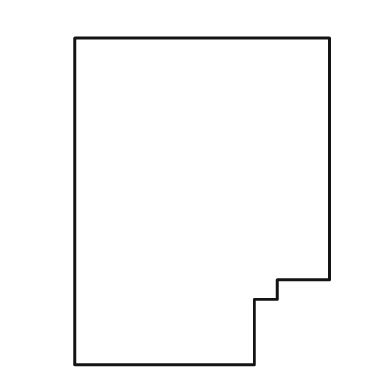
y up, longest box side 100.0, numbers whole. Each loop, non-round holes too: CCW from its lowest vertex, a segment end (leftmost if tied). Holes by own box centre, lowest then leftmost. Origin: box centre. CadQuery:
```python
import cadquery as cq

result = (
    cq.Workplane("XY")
    .moveTo(-39.0, -50.0)
    .lineTo(16.0, -50.0)
    .lineTo(16.0, -30.0)
    .lineTo(23.0, -30.0)
    .lineTo(23.0, -24.0)
    .lineTo(39.0, -24.0)
    .lineTo(39.0, 50.0)
    .lineTo(-39.0, 50.0)
    .close()
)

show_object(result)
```